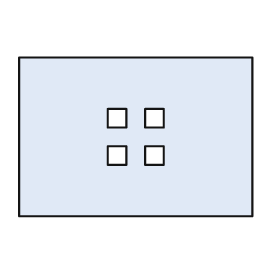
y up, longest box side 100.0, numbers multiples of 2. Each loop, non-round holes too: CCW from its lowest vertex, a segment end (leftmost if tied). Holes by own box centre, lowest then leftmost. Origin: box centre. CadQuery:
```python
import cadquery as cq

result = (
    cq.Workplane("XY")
    .moveTo(-50.0, -34.0)
    .lineTo(50.0, -34.0)
    .lineTo(50.0, 34.0)
    .lineTo(-50.0, 34.0)
    .close()
    .moveTo(-12.0, -12.0)
    .lineTo(-4.0, -12.0)
    .lineTo(-4.0, -4.0)
    .lineTo(-12.0, -4.0)
    .close()
    .moveTo(4.0, -12.0)
    .lineTo(12.0, -12.0)
    .lineTo(12.0, -4.0)
    .lineTo(4.0, -4.0)
    .close()
    .moveTo(-12.0, 4.0)
    .lineTo(-4.0, 4.0)
    .lineTo(-4.0, 12.0)
    .lineTo(-12.0, 12.0)
    .close()
    .moveTo(4.0, 4.0)
    .lineTo(12.0, 4.0)
    .lineTo(12.0, 12.0)
    .lineTo(4.0, 12.0)
    .close()
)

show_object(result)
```